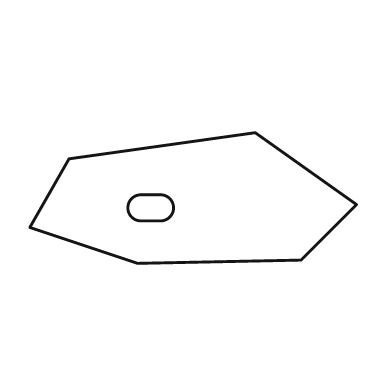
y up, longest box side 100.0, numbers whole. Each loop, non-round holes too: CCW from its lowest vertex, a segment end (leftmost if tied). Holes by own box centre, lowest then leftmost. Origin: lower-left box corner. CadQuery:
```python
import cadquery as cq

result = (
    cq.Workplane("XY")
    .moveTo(33.0, 0.0)
    .lineTo(83.0, 1.0)
    .lineTo(100.0, 18.0)
    .lineTo(69.0, 40.0)
    .lineTo(12.0, 32.0)
    .lineTo(0.0, 11.0)
    .close()
    .moveTo(34.0, 13.0)
    .lineTo(40.0, 13.0)
    .threePointArc((44.0, 17.0), (40.0, 21.0))
    .lineTo(34.0, 21.0)
    .threePointArc((30.0, 17.0), (34.0, 13.0))
    .close()
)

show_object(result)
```